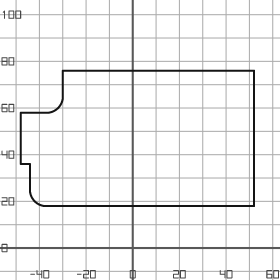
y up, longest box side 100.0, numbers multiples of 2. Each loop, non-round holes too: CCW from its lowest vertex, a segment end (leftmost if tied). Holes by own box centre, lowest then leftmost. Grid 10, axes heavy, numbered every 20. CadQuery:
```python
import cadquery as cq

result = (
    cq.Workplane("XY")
    .moveTo(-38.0, 18.0)
    .lineTo(52.0, 18.0)
    .lineTo(52.0, 76.0)
    .lineTo(-30.0, 76.0)
    .lineTo(-30.0, 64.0)
    .threePointArc((-32.0, 60.0), (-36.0, 58.0))
    .lineTo(-48.0, 58.0)
    .lineTo(-48.0, 36.0)
    .lineTo(-44.0, 36.0)
    .lineTo(-44.0, 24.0)
    .threePointArc((-42.0, 20.0), (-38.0, 18.0))
    .close()
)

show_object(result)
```